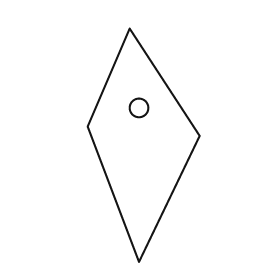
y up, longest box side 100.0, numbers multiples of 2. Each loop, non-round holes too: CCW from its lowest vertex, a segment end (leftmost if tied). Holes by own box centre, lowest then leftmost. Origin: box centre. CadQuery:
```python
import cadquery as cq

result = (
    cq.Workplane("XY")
    .moveTo(-2.0, -50.0)
    .lineTo(24.0, 4.0)
    .lineTo(-6.0, 50.0)
    .lineTo(-24.0, 8.0)
    .close()
    .moveTo(-2.0, 16.0)
    .circle(4.0)
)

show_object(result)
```